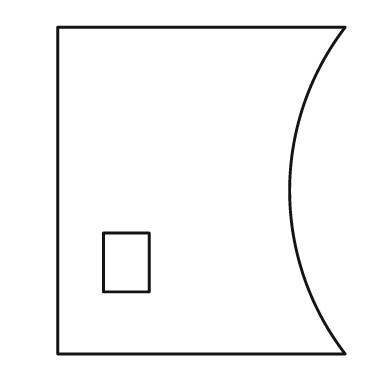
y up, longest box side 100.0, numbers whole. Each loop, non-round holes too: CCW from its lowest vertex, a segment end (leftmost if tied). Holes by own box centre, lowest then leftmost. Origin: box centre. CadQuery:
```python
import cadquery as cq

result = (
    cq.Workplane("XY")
    .moveTo(-44.0, -50.0)
    .lineTo(44.0, -50.0)
    .threePointArc((27.0, 0.0), (44.0, 50.0))
    .lineTo(-44.0, 50.0)
    .close()
    .moveTo(-30.0, -31.0)
    .lineTo(-16.0, -31.0)
    .lineTo(-16.0, -13.0)
    .lineTo(-30.0, -13.0)
    .close()
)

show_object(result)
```